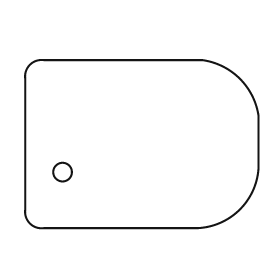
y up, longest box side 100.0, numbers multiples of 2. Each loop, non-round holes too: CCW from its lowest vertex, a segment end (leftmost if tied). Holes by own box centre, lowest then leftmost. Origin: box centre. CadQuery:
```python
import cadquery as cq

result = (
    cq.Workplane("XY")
    .moveTo(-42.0, -36.0)
    .lineTo(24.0, -36.0)
    .threePointArc((42.0, -28.0), (50.0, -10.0))
    .lineTo(50.0, 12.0)
    .threePointArc((42.0, 28.0), (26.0, 36.0))
    .lineTo(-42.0, 36.0)
    .threePointArc((-48.0, 34.0), (-50.0, 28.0))
    .lineTo(-50.0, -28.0)
    .threePointArc((-48.0, -34.0), (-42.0, -36.0))
    .close()
    .moveTo(-34.0, -12.0)
    .circle(4.0)
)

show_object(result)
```